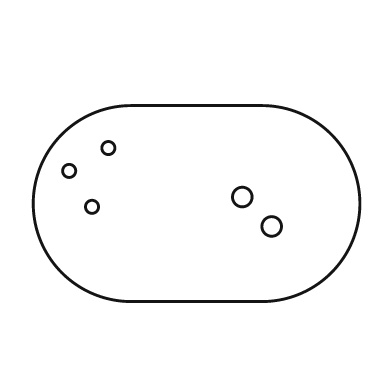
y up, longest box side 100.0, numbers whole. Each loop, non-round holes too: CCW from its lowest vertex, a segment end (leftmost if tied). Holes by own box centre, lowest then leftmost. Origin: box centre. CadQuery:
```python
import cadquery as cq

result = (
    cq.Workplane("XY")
    .moveTo(-20.0, -30.0)
    .lineTo(20.0, -30.0)
    .threePointArc((50.0, 0.0), (20.0, 30.0))
    .lineTo(-20.0, 30.0)
    .threePointArc((-50.0, 0.0), (-20.0, -30.0))
    .close()
    .moveTo(23.0, -7.0)
    .circle(3.0)
    .moveTo(-32.0, -1.0)
    .circle(2.0)
    .moveTo(14.0, 2.0)
    .circle(3.0)
    .moveTo(-39.0, 10.0)
    .circle(2.0)
    .moveTo(-27.0, 17.0)
    .circle(2.0)
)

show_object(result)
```